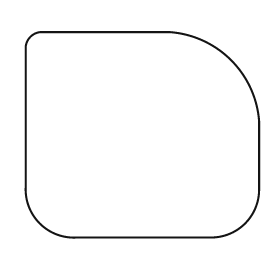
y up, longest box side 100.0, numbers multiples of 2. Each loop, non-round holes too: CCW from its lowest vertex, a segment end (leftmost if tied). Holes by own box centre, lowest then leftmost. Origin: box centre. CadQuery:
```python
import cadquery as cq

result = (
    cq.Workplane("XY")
    .moveTo(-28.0, -44.0)
    .lineTo(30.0, -44.0)
    .threePointArc((44.0, -38.0), (50.0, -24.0))
    .lineTo(50.0, 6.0)
    .threePointArc((38.0, 32.0), (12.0, 44.0))
    .lineTo(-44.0, 44.0)
    .threePointArc((-48.0, 42.0), (-50.0, 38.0))
    .lineTo(-50.0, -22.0)
    .threePointArc((-44.0, -38.0), (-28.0, -44.0))
    .close()
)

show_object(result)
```